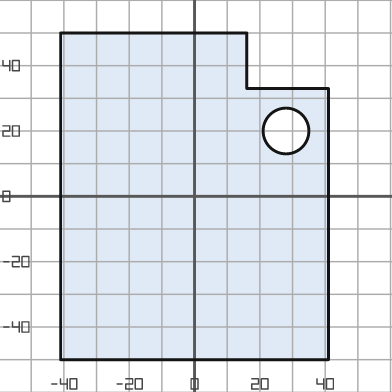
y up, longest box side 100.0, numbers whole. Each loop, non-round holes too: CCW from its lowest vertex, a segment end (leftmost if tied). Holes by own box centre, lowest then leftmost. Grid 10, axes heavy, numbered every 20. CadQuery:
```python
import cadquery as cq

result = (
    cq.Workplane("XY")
    .moveTo(-41.0, -50.0)
    .lineTo(41.0, -50.0)
    .lineTo(41.0, 33.0)
    .lineTo(16.0, 33.0)
    .lineTo(16.0, 50.0)
    .lineTo(-41.0, 50.0)
    .close()
    .moveTo(28.0, 20.0)
    .circle(7.0)
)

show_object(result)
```